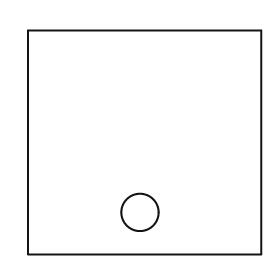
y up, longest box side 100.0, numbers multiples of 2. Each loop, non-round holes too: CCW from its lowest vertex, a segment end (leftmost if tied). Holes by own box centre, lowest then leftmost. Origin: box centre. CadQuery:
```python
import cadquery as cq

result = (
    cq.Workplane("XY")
    .moveTo(-50.0, -48.0)
    .lineTo(50.0, -48.0)
    .lineTo(50.0, 48.0)
    .lineTo(-50.0, 48.0)
    .close()
    .moveTo(-2.0, -30.0)
    .circle(8.0)
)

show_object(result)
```